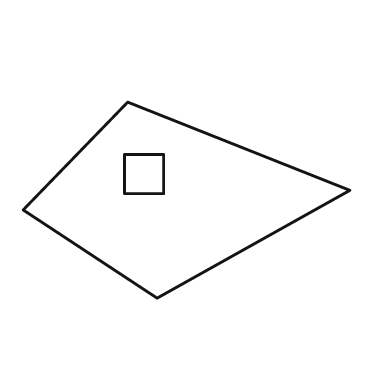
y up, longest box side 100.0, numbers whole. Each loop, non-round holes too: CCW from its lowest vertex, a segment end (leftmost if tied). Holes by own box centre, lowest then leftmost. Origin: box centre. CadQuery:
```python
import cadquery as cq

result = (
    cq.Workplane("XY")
    .moveTo(-9.0, -30.0)
    .lineTo(50.0, 3.0)
    .lineTo(-18.0, 30.0)
    .lineTo(-50.0, -3.0)
    .close()
    .moveTo(-19.0, 2.0)
    .lineTo(-7.0, 2.0)
    .lineTo(-7.0, 14.0)
    .lineTo(-19.0, 14.0)
    .close()
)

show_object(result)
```